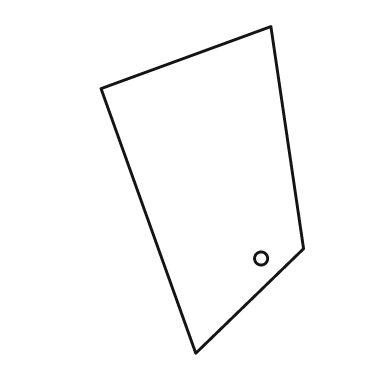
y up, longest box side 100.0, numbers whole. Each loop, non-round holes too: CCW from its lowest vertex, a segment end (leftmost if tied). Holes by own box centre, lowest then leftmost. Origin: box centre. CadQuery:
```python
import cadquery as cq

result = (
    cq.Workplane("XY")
    .moveTo(-2.0, -50.0)
    .lineTo(31.0, -18.0)
    .lineTo(21.0, 50.0)
    .lineTo(-31.0, 31.0)
    .close()
    .moveTo(18.0, -21.0)
    .circle(2.0)
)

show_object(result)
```